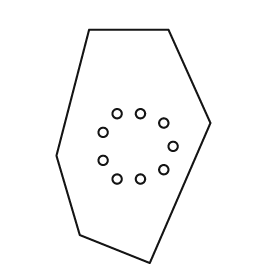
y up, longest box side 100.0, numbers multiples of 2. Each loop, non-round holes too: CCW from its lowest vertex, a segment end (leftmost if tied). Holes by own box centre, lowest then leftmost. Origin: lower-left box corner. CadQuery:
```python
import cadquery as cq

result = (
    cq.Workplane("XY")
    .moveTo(40.0, 0.0)
    .lineTo(66.0, 60.0)
    .lineTo(48.0, 100.0)
    .lineTo(14.0, 100.0)
    .lineTo(0.0, 46.0)
    .lineTo(10.0, 12.0)
    .close()
    .moveTo(26.0, 36.0)
    .circle(2.0)
    .moveTo(36.0, 36.0)
    .circle(2.0)
    .moveTo(46.0, 40.0)
    .circle(2.0)
    .moveTo(20.0, 44.0)
    .circle(2.0)
    .moveTo(50.0, 50.0)
    .circle(2.0)
    .moveTo(20.0, 56.0)
    .circle(2.0)
    .moveTo(46.0, 60.0)
    .circle(2.0)
    .moveTo(26.0, 64.0)
    .circle(2.0)
    .moveTo(36.0, 64.0)
    .circle(2.0)
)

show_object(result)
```